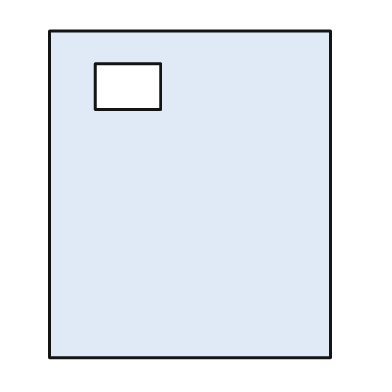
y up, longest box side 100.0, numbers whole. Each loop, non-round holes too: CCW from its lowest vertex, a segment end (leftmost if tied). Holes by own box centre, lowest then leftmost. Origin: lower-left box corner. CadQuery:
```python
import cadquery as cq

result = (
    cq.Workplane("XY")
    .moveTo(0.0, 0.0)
    .lineTo(86.0, 0.0)
    .lineTo(86.0, 100.0)
    .lineTo(0.0, 100.0)
    .close()
    .moveTo(14.0, 76.0)
    .lineTo(34.0, 76.0)
    .lineTo(34.0, 90.0)
    .lineTo(14.0, 90.0)
    .close()
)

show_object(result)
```